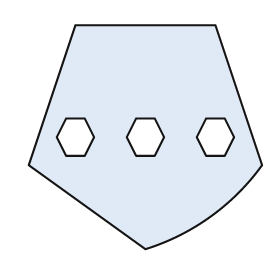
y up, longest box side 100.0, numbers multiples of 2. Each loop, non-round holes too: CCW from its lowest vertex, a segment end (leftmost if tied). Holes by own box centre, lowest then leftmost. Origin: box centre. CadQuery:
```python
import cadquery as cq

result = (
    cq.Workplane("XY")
    .moveTo(0.0, -48.0)
    .threePointArc((28.0, -34.0), (50.0, -12.0))
    .lineTo(30.0, 48.0)
    .lineTo(-30.0, 48.0)
    .lineTo(-50.0, -12.0)
    .close()
    .moveTo(-34.0, -8.0)
    .lineTo(-26.0, -8.0)
    .lineTo(-22.0, 0.0)
    .lineTo(-26.0, 8.0)
    .lineTo(-34.0, 8.0)
    .lineTo(-38.0, 0.0)
    .close()
    .moveTo(-4.0, -8.0)
    .lineTo(4.0, -8.0)
    .lineTo(8.0, 0.0)
    .lineTo(4.0, 8.0)
    .lineTo(-4.0, 8.0)
    .lineTo(-8.0, 0.0)
    .close()
    .moveTo(26.0, -8.0)
    .lineTo(34.0, -8.0)
    .lineTo(38.0, 0.0)
    .lineTo(34.0, 8.0)
    .lineTo(26.0, 8.0)
    .lineTo(22.0, 0.0)
    .close()
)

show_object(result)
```